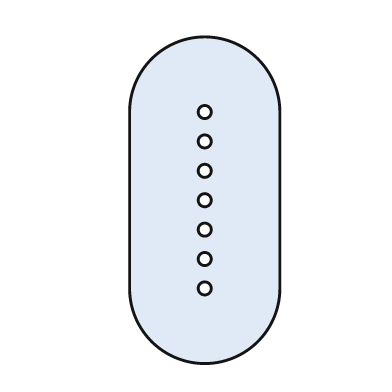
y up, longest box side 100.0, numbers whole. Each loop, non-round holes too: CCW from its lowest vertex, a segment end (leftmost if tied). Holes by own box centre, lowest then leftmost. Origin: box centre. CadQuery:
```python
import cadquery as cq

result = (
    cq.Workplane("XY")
    .moveTo(-23.0, -27.0)
    .threePointArc((0.0, -50.0), (23.0, -27.0))
    .lineTo(23.0, 27.0)
    .threePointArc((0.0, 50.0), (-23.0, 27.0))
    .close()
    .moveTo(0.0, -27.0)
    .circle(2.0)
    .moveTo(0.0, -18.0)
    .circle(2.0)
    .moveTo(0.0, -9.0)
    .circle(2.0)
    .moveTo(0.0, 0.0)
    .circle(2.0)
    .moveTo(0.0, 9.0)
    .circle(2.0)
    .moveTo(0.0, 18.0)
    .circle(2.0)
    .moveTo(0.0, 27.0)
    .circle(2.0)
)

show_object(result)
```